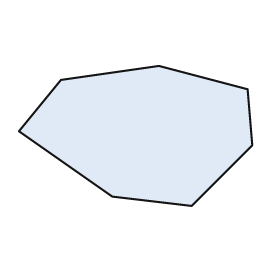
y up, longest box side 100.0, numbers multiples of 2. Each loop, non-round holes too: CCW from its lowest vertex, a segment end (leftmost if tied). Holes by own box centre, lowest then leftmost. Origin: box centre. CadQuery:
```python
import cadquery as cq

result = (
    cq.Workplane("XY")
    .moveTo(24.0, -30.0)
    .lineTo(50.0, -4.0)
    .lineTo(48.0, 20.0)
    .lineTo(10.0, 30.0)
    .lineTo(-32.0, 24.0)
    .lineTo(-50.0, 2.0)
    .lineTo(-10.0, -26.0)
    .close()
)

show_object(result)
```